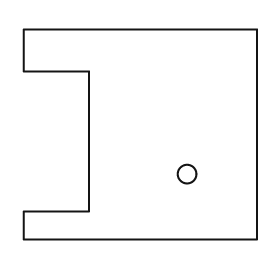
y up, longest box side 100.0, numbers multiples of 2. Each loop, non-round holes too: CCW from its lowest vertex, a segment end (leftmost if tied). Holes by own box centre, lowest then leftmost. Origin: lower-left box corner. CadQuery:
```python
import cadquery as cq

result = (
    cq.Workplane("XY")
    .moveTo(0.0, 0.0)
    .lineTo(100.0, 0.0)
    .lineTo(100.0, 90.0)
    .lineTo(0.0, 90.0)
    .lineTo(0.0, 72.0)
    .lineTo(28.0, 72.0)
    .lineTo(28.0, 12.0)
    .lineTo(0.0, 12.0)
    .close()
    .moveTo(70.0, 28.0)
    .circle(4.0)
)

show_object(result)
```